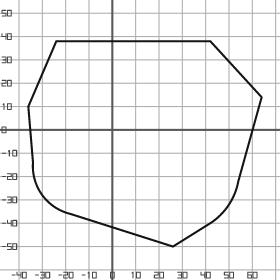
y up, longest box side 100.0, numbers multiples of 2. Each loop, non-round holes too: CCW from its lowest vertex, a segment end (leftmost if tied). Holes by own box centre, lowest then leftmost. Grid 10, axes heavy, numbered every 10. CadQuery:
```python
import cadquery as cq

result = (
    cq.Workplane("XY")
    .moveTo(26.0, -50.0)
    .lineTo(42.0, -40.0)
    .threePointArc((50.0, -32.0), (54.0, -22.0))
    .lineTo(64.0, 14.0)
    .lineTo(42.0, 38.0)
    .lineTo(-24.0, 38.0)
    .lineTo(-36.0, 10.0)
    .lineTo(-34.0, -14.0)
    .threePointArc((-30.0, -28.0), (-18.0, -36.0))
    .close()
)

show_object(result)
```